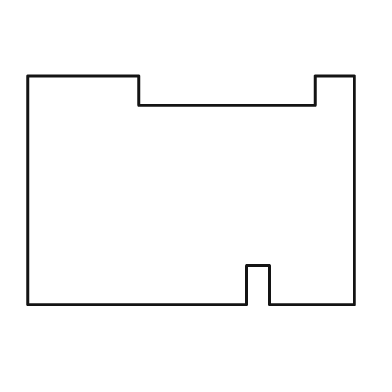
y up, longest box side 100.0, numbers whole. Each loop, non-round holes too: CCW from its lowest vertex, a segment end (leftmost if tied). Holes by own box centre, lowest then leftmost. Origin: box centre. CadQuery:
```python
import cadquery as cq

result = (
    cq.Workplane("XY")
    .moveTo(-50.0, -35.0)
    .lineTo(17.0, -35.0)
    .lineTo(17.0, -23.0)
    .lineTo(24.0, -23.0)
    .lineTo(24.0, -35.0)
    .lineTo(50.0, -35.0)
    .lineTo(50.0, 35.0)
    .lineTo(38.0, 35.0)
    .lineTo(38.0, 26.0)
    .lineTo(-16.0, 26.0)
    .lineTo(-16.0, 35.0)
    .lineTo(-50.0, 35.0)
    .close()
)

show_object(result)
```